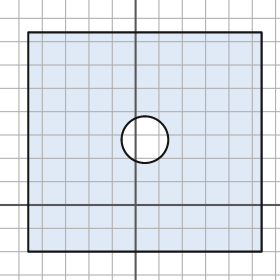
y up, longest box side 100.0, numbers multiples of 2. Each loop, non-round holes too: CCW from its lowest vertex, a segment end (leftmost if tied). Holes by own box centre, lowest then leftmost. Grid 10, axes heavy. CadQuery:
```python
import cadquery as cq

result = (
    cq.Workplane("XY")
    .moveTo(-46.0, -20.0)
    .lineTo(54.0, -20.0)
    .lineTo(54.0, 74.0)
    .lineTo(-46.0, 74.0)
    .close()
    .moveTo(4.0, 28.0)
    .circle(10.0)
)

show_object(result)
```